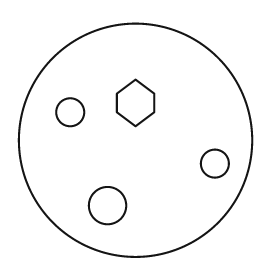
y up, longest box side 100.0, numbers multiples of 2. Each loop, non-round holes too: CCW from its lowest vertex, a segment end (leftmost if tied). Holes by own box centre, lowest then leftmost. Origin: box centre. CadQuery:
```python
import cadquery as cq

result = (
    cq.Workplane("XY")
    .moveTo(0.0, 0.0)
    .circle(50.0)
    .moveTo(-12.0, -28.0)
    .circle(8.0)
    .moveTo(34.0, -10.0)
    .circle(6.0)
    .moveTo(-28.0, 12.0)
    .circle(6.0)
    .moveTo(0.0, 6.0)
    .lineTo(8.0, 12.0)
    .lineTo(8.0, 20.0)
    .lineTo(0.0, 26.0)
    .lineTo(-8.0, 20.0)
    .lineTo(-8.0, 12.0)
    .close()
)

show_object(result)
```